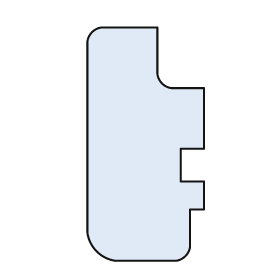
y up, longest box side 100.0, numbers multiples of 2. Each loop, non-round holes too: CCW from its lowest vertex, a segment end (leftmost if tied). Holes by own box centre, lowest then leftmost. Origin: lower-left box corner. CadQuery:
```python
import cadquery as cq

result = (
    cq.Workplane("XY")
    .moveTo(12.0, 0.0)
    .lineTo(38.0, 0.0)
    .threePointArc((42.0, 2.0), (44.0, 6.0))
    .lineTo(44.0, 22.0)
    .lineTo(50.0, 22.0)
    .lineTo(50.0, 34.0)
    .lineTo(40.0, 34.0)
    .lineTo(40.0, 48.0)
    .lineTo(50.0, 48.0)
    .lineTo(50.0, 74.0)
    .lineTo(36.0, 74.0)
    .threePointArc((32.0, 76.0), (30.0, 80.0))
    .lineTo(30.0, 100.0)
    .lineTo(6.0, 100.0)
    .threePointArc((2.0, 98.0), (0.0, 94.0))
    .lineTo(0.0, 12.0)
    .threePointArc((4.0, 4.0), (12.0, 0.0))
    .close()
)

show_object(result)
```